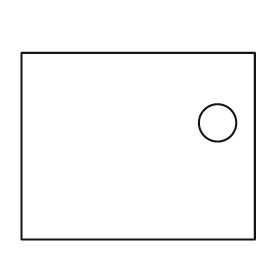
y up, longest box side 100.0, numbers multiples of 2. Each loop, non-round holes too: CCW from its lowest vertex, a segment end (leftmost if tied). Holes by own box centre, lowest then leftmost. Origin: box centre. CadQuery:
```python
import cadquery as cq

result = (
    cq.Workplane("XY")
    .moveTo(-50.0, -40.0)
    .lineTo(50.0, -40.0)
    .lineTo(50.0, 40.0)
    .lineTo(-50.0, 40.0)
    .close()
    .moveTo(34.0, 10.0)
    .circle(8.0)
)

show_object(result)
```